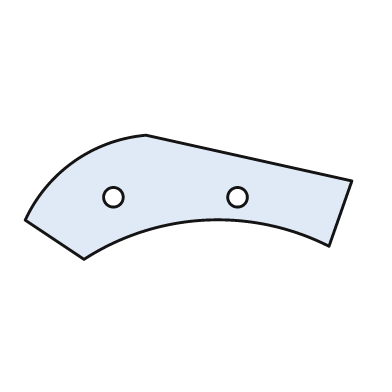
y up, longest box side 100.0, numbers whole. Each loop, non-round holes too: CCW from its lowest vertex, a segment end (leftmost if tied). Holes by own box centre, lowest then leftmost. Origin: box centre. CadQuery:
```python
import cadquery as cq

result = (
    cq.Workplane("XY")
    .moveTo(-32.0, -19.0)
    .threePointArc((5.0, -7.0), (43.0, -15.0))
    .lineTo(50.0, 5.0)
    .lineTo(-13.0, 19.0)
    .threePointArc((-35.0, 11.0), (-50.0, -7.0))
    .close()
    .moveTo(-23.0, 0.0)
    .circle(3.0)
    .moveTo(15.0, 0.0)
    .circle(3.0)
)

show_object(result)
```